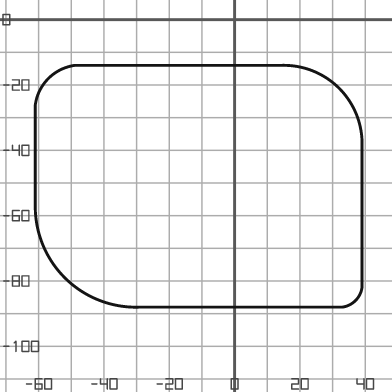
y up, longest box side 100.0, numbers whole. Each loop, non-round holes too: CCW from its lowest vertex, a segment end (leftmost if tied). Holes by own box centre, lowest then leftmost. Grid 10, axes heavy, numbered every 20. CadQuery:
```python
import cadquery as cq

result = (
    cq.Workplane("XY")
    .moveTo(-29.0, -88.0)
    .lineTo(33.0, -88.0)
    .threePointArc((37.0, -86.0), (39.0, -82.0))
    .lineTo(39.0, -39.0)
    .threePointArc((32.0, -21.0), (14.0, -14.0))
    .lineTo(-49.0, -14.0)
    .threePointArc((-57.0, -18.0), (-61.0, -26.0))
    .lineTo(-61.0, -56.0)
    .threePointArc((-52.0, -79.0), (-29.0, -88.0))
    .close()
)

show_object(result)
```